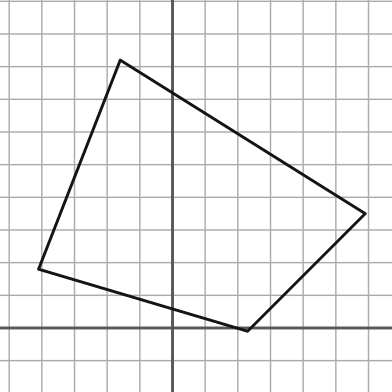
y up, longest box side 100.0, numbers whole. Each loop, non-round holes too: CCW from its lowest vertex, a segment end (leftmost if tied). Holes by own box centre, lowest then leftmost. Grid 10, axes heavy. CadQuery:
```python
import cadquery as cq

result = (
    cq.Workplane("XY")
    .moveTo(23.0, -1.0)
    .lineTo(59.0, 35.0)
    .lineTo(-16.0, 82.0)
    .lineTo(-41.0, 18.0)
    .close()
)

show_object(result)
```